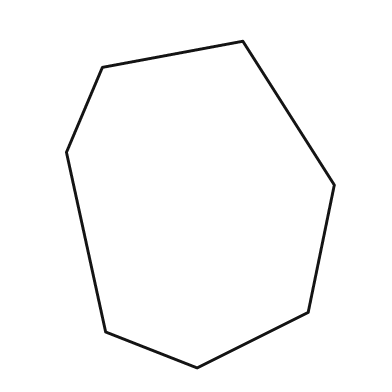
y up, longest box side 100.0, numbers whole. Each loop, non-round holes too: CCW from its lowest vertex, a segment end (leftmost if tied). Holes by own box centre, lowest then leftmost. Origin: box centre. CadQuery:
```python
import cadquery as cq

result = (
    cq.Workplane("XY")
    .moveTo(-1.0, -50.0)
    .lineTo(33.0, -33.0)
    .lineTo(41.0, 6.0)
    .lineTo(13.0, 50.0)
    .lineTo(-30.0, 42.0)
    .lineTo(-41.0, 16.0)
    .lineTo(-29.0, -39.0)
    .close()
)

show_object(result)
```